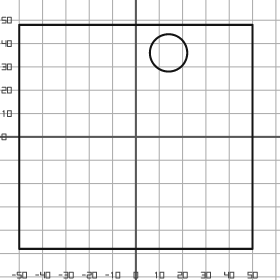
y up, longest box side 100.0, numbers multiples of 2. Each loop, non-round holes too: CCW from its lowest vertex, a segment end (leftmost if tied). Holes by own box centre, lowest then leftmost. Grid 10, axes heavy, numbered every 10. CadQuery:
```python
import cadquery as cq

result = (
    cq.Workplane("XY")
    .moveTo(-50.0, -48.0)
    .lineTo(50.0, -48.0)
    .lineTo(50.0, 48.0)
    .lineTo(-50.0, 48.0)
    .close()
    .moveTo(14.0, 36.0)
    .circle(8.0)
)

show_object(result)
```